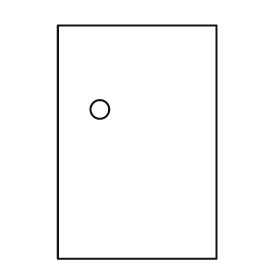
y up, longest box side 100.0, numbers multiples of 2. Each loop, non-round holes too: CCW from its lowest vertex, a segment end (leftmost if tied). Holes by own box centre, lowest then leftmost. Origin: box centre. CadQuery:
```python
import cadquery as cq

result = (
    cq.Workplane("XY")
    .moveTo(-34.0, -50.0)
    .lineTo(34.0, -50.0)
    .lineTo(34.0, 50.0)
    .lineTo(-34.0, 50.0)
    .close()
    .moveTo(-16.0, 14.0)
    .circle(4.0)
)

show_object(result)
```